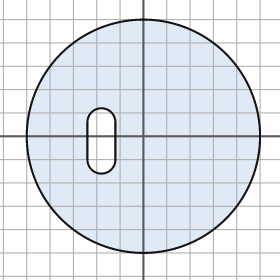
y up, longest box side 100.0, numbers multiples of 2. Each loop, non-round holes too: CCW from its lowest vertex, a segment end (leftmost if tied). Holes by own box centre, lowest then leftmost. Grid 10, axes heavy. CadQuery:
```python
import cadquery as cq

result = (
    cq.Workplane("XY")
    .moveTo(0.0, 0.0)
    .circle(50.0)
    .moveTo(-24.0, -10.0)
    .threePointArc((-18.0, -16.0), (-12.0, -10.0))
    .lineTo(-12.0, 6.0)
    .threePointArc((-18.0, 12.0), (-24.0, 6.0))
    .close()
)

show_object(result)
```